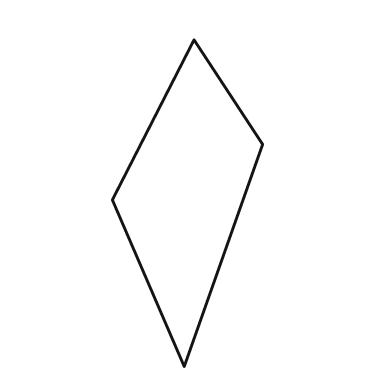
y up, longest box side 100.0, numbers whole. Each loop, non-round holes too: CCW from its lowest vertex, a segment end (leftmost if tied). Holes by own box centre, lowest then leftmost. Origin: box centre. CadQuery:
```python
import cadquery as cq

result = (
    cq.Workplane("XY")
    .moveTo(-1.0, -50.0)
    .lineTo(23.0, 18.0)
    .lineTo(2.0, 50.0)
    .lineTo(-23.0, 1.0)
    .close()
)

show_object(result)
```